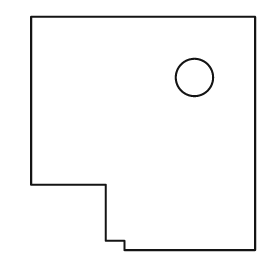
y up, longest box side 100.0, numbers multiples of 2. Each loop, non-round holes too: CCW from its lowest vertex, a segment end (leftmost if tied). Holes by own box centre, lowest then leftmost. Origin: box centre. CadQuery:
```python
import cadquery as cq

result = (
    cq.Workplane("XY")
    .moveTo(-8.0, -50.0)
    .lineTo(48.0, -50.0)
    .lineTo(48.0, 50.0)
    .lineTo(-48.0, 50.0)
    .lineTo(-48.0, -22.0)
    .lineTo(-16.0, -22.0)
    .lineTo(-16.0, -46.0)
    .lineTo(-8.0, -46.0)
    .close()
    .moveTo(22.0, 24.0)
    .circle(8.0)
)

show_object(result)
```